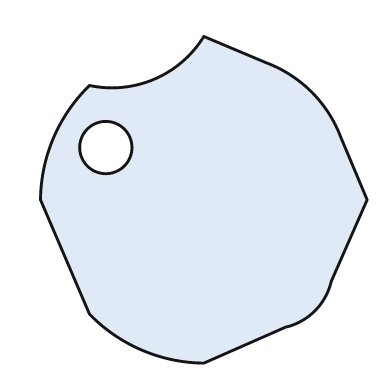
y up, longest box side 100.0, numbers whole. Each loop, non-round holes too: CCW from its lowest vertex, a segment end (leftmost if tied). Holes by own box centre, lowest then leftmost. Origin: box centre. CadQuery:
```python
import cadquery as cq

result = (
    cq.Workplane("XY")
    .moveTo(0.0, -50.0)
    .lineTo(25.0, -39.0)
    .threePointArc((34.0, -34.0), (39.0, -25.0))
    .lineTo(50.0, 0.0)
    .lineTo(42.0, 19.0)
    .threePointArc((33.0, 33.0), (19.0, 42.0))
    .lineTo(0.0, 50.0)
    .threePointArc((-15.0, 37.0), (-35.0, 35.0))
    .threePointArc((-46.0, 19.0), (-50.0, 0.0))
    .lineTo(-35.0, -35.0)
    .threePointArc((-19.0, -46.0), (0.0, -50.0))
    .close()
    .moveTo(-30.0, 16.0)
    .circle(8.0)
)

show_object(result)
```